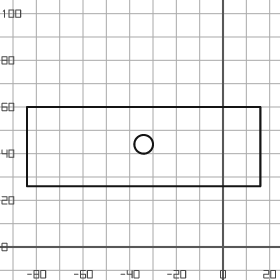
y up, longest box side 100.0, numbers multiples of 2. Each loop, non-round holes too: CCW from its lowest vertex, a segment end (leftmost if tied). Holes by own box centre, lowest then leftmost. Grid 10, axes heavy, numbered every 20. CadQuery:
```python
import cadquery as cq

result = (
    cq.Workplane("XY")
    .moveTo(-84.0, 26.0)
    .lineTo(16.0, 26.0)
    .lineTo(16.0, 60.0)
    .lineTo(-84.0, 60.0)
    .close()
    .moveTo(-34.0, 44.0)
    .circle(4.0)
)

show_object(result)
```